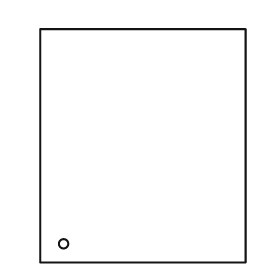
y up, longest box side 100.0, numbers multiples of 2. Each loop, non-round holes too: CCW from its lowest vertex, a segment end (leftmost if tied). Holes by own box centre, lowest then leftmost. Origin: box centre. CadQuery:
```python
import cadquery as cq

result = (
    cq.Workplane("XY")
    .moveTo(-44.0, -50.0)
    .lineTo(44.0, -50.0)
    .lineTo(44.0, 50.0)
    .lineTo(-44.0, 50.0)
    .close()
    .moveTo(-34.0, -42.0)
    .circle(2.0)
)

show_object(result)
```